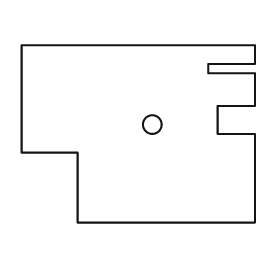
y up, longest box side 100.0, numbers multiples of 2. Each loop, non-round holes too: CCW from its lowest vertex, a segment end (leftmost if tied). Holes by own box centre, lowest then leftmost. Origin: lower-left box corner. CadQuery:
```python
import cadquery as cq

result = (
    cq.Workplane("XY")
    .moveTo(24.0, 0.0)
    .lineTo(100.0, 0.0)
    .lineTo(100.0, 38.0)
    .lineTo(84.0, 38.0)
    .lineTo(84.0, 50.0)
    .lineTo(100.0, 50.0)
    .lineTo(100.0, 64.0)
    .lineTo(80.0, 64.0)
    .lineTo(80.0, 68.0)
    .lineTo(100.0, 68.0)
    .lineTo(100.0, 76.0)
    .lineTo(0.0, 76.0)
    .lineTo(0.0, 30.0)
    .lineTo(24.0, 30.0)
    .close()
    .moveTo(56.0, 42.0)
    .circle(4.0)
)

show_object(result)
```